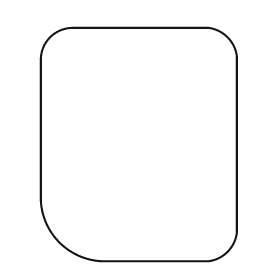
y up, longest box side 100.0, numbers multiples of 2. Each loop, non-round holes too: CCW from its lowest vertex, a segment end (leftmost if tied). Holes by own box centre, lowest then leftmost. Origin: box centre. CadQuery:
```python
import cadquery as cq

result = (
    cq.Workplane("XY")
    .moveTo(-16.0, -50.0)
    .lineTo(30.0, -50.0)
    .threePointArc((38.0, -46.0), (42.0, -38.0))
    .lineTo(42.0, 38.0)
    .threePointArc((38.0, 46.0), (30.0, 50.0))
    .lineTo(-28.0, 50.0)
    .threePointArc((-38.0, 46.0), (-42.0, 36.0))
    .lineTo(-42.0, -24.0)
    .threePointArc((-34.0, -42.0), (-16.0, -50.0))
    .close()
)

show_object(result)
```